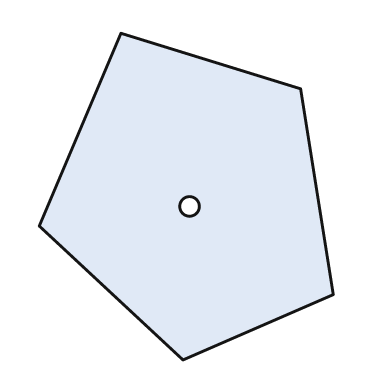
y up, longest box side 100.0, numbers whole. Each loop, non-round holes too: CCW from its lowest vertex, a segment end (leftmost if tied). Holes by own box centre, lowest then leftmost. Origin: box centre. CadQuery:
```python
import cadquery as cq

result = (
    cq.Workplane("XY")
    .moveTo(-1.0, -50.0)
    .lineTo(45.0, -30.0)
    .lineTo(35.0, 33.0)
    .lineTo(-20.0, 50.0)
    .lineTo(-45.0, -9.0)
    .close()
    .moveTo(1.0, -3.0)
    .circle(3.0)
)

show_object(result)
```